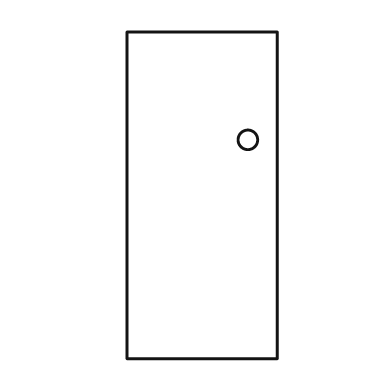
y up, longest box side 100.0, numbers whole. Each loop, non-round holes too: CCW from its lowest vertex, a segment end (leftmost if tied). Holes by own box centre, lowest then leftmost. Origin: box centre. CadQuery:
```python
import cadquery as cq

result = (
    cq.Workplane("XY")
    .moveTo(-23.0, -50.0)
    .lineTo(23.0, -50.0)
    .lineTo(23.0, 50.0)
    .lineTo(-23.0, 50.0)
    .close()
    .moveTo(14.0, 17.0)
    .circle(3.0)
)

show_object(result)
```